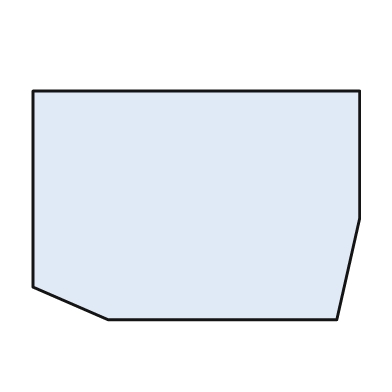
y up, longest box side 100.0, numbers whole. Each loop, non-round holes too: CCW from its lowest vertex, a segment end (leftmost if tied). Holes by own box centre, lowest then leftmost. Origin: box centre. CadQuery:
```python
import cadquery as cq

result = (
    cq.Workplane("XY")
    .moveTo(-27.0, -35.0)
    .lineTo(43.0, -35.0)
    .lineTo(50.0, -4.0)
    .lineTo(50.0, 35.0)
    .lineTo(-50.0, 35.0)
    .lineTo(-50.0, -25.0)
    .close()
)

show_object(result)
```